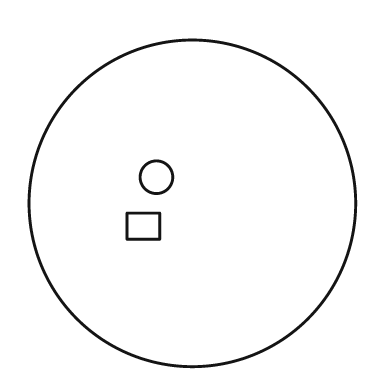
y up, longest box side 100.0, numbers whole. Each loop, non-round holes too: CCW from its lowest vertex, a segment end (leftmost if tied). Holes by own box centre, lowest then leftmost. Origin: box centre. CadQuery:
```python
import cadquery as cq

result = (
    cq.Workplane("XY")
    .moveTo(0.0, 0.0)
    .circle(50.0)
    .moveTo(-20.0, -11.0)
    .lineTo(-10.0, -11.0)
    .lineTo(-10.0, -3.0)
    .lineTo(-20.0, -3.0)
    .close()
    .moveTo(-11.0, 8.0)
    .circle(5.0)
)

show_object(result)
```